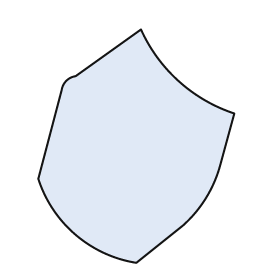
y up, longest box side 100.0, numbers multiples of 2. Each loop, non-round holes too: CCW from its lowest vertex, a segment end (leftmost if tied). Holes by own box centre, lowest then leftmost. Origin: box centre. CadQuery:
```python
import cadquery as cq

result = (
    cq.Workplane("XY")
    .moveTo(0.0, -50.0)
    .lineTo(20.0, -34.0)
    .threePointArc((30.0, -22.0), (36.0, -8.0))
    .lineTo(42.0, 14.0)
    .threePointArc((18.0, 28.0), (2.0, 50.0))
    .lineTo(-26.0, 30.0)
    .threePointArc((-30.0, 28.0), (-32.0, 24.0))
    .lineTo(-42.0, -14.0)
    .threePointArc((-26.0, -38.0), (0.0, -50.0))
    .close()
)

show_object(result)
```